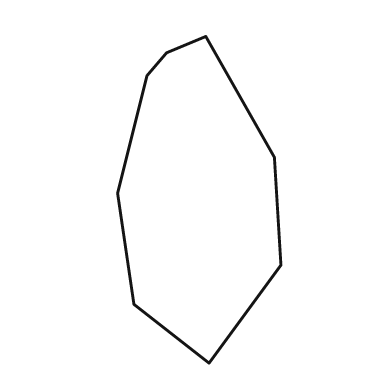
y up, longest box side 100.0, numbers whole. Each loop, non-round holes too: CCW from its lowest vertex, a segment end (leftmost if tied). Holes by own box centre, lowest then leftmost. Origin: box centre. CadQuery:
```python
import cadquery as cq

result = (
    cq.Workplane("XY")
    .moveTo(3.0, -50.0)
    .lineTo(25.0, -20.0)
    .lineTo(23.0, 13.0)
    .lineTo(2.0, 50.0)
    .lineTo(-10.0, 45.0)
    .lineTo(-16.0, 38.0)
    .lineTo(-25.0, 2.0)
    .lineTo(-20.0, -32.0)
    .close()
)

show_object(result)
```